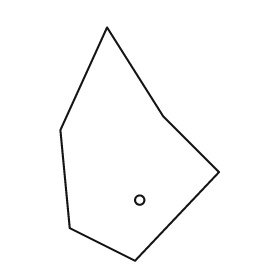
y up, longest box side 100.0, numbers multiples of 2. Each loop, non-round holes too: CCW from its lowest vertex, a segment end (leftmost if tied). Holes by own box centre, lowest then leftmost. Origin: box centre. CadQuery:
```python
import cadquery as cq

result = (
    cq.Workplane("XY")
    .moveTo(-2.0, -50.0)
    .lineTo(34.0, -12.0)
    .lineTo(10.0, 12.0)
    .lineTo(-14.0, 50.0)
    .lineTo(-34.0, 6.0)
    .lineTo(-30.0, -36.0)
    .close()
    .moveTo(0.0, -24.0)
    .circle(2.0)
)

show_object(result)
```